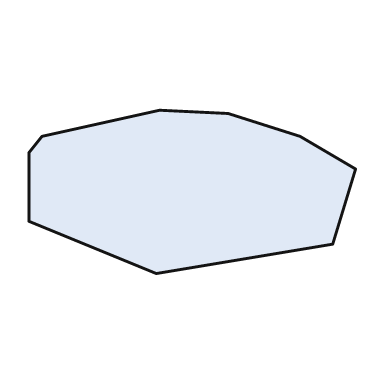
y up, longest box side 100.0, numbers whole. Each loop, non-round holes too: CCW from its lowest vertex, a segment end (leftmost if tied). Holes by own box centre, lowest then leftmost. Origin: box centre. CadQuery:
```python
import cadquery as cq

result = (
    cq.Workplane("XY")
    .moveTo(-11.0, -25.0)
    .lineTo(43.0, -16.0)
    .lineTo(50.0, 7.0)
    .lineTo(33.0, 17.0)
    .lineTo(11.0, 24.0)
    .lineTo(-10.0, 25.0)
    .lineTo(-46.0, 17.0)
    .lineTo(-50.0, 12.0)
    .lineTo(-50.0, -9.0)
    .close()
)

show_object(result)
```